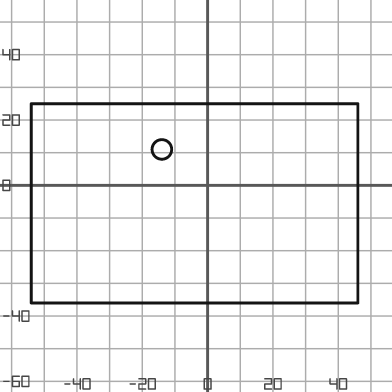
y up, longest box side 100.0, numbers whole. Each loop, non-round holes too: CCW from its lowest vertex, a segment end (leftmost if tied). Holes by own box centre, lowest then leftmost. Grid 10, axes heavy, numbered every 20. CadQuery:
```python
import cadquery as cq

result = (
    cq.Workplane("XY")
    .moveTo(-54.0, -36.0)
    .lineTo(46.0, -36.0)
    .lineTo(46.0, 25.0)
    .lineTo(-54.0, 25.0)
    .close()
    .moveTo(-14.0, 11.0)
    .circle(3.0)
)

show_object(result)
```